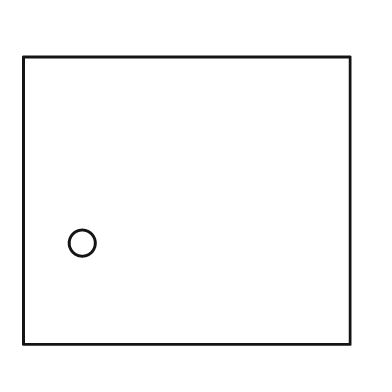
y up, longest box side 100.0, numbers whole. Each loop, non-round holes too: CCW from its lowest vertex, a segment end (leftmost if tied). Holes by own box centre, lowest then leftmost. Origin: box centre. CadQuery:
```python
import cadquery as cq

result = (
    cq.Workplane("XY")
    .moveTo(-50.0, -44.0)
    .lineTo(50.0, -44.0)
    .lineTo(50.0, 44.0)
    .lineTo(-50.0, 44.0)
    .close()
    .moveTo(-32.0, -13.0)
    .circle(4.0)
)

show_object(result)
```